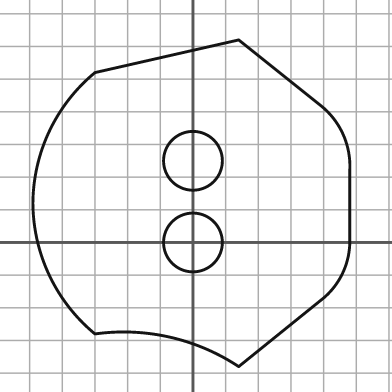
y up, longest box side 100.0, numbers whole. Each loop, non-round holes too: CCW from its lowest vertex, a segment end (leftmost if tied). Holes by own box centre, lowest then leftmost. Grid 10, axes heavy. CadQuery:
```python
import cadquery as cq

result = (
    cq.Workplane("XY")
    .moveTo(14.0, -38.0)
    .lineTo(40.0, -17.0)
    .threePointArc((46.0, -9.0), (48.0, 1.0))
    .lineTo(48.0, 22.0)
    .threePointArc((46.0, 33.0), (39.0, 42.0))
    .lineTo(14.0, 62.0)
    .lineTo(-30.0, 52.0)
    .threePointArc((-44.0, 34.0), (-49.0, 12.0))
    .threePointArc((-44.0, -10.0), (-30.0, -28.0))
    .threePointArc((-7.0, -29.0), (14.0, -38.0))
    .close()
    .moveTo(0.0, 0.0)
    .circle(9.0)
    .moveTo(0.0, 25.0)
    .circle(9.0)
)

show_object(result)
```